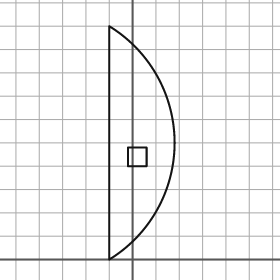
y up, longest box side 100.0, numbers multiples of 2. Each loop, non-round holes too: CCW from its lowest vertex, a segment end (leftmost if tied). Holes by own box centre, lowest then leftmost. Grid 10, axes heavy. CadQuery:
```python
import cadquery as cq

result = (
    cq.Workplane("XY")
    .moveTo(-10.0, 0.0)
    .threePointArc((18.0, 50.0), (-10.0, 100.0))
    .close()
    .moveTo(-2.0, 40.0)
    .lineTo(6.0, 40.0)
    .lineTo(6.0, 48.0)
    .lineTo(-2.0, 48.0)
    .close()
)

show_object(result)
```